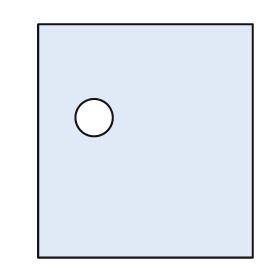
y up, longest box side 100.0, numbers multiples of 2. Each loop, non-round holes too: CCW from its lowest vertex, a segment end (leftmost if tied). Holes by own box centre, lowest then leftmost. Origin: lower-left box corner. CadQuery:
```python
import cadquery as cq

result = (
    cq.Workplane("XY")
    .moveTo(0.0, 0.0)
    .lineTo(92.0, 0.0)
    .lineTo(92.0, 100.0)
    .lineTo(0.0, 100.0)
    .close()
    .moveTo(24.0, 60.0)
    .circle(8.0)
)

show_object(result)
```